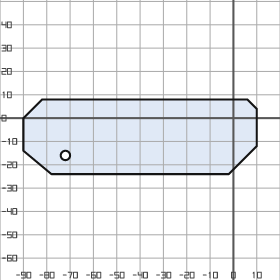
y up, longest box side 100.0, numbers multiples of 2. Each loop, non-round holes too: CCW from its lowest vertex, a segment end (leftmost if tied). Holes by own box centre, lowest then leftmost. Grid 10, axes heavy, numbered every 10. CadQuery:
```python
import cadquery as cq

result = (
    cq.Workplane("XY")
    .moveTo(-78.0, -24.0)
    .lineTo(-2.0, -24.0)
    .lineTo(10.0, -12.0)
    .lineTo(10.0, 4.0)
    .lineTo(6.0, 8.0)
    .lineTo(-82.0, 8.0)
    .lineTo(-90.0, 0.0)
    .lineTo(-90.0, -14.0)
    .close()
    .moveTo(-72.0, -16.0)
    .circle(2.0)
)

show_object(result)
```